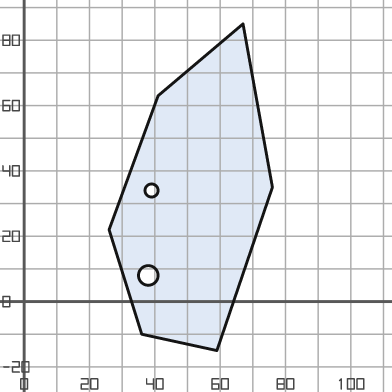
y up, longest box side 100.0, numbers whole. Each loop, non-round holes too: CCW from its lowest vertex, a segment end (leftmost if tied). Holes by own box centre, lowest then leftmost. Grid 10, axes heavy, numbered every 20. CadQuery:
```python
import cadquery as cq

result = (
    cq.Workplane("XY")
    .moveTo(59.0, -15.0)
    .lineTo(76.0, 35.0)
    .lineTo(67.0, 85.0)
    .lineTo(41.0, 63.0)
    .lineTo(26.0, 22.0)
    .lineTo(36.0, -10.0)
    .close()
    .moveTo(38.0, 8.0)
    .circle(3.0)
    .moveTo(39.0, 34.0)
    .circle(2.0)
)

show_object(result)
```